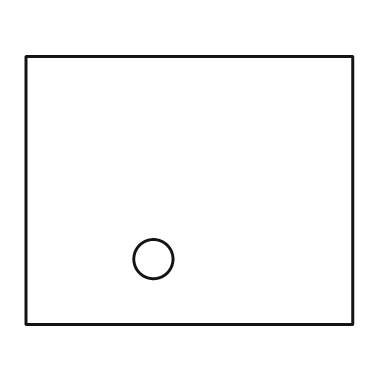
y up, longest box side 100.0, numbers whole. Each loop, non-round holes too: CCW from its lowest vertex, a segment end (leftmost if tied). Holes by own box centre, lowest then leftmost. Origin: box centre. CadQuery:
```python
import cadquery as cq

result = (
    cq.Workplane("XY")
    .moveTo(-50.0, -41.0)
    .lineTo(50.0, -41.0)
    .lineTo(50.0, 41.0)
    .lineTo(-50.0, 41.0)
    .close()
    .moveTo(-11.0, -21.0)
    .circle(6.0)
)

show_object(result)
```